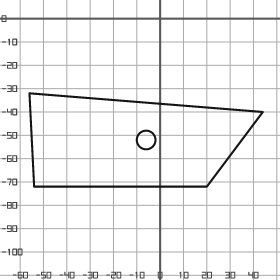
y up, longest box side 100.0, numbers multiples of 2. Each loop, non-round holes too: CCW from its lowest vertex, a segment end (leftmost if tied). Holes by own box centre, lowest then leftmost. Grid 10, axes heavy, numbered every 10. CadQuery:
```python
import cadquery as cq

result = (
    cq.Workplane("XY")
    .moveTo(-54.0, -72.0)
    .lineTo(20.0, -72.0)
    .lineTo(44.0, -40.0)
    .lineTo(-56.0, -32.0)
    .close()
    .moveTo(-6.0, -52.0)
    .circle(4.0)
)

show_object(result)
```